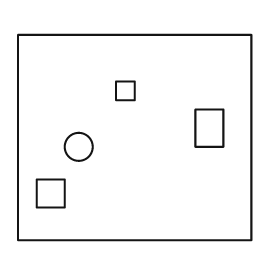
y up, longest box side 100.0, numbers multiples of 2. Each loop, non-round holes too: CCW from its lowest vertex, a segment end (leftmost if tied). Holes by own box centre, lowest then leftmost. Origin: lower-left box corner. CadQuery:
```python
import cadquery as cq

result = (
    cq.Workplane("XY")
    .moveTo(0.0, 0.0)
    .lineTo(100.0, 0.0)
    .lineTo(100.0, 88.0)
    .lineTo(0.0, 88.0)
    .close()
    .moveTo(8.0, 14.0)
    .lineTo(20.0, 14.0)
    .lineTo(20.0, 26.0)
    .lineTo(8.0, 26.0)
    .close()
    .moveTo(26.0, 40.0)
    .circle(6.0)
    .moveTo(76.0, 40.0)
    .lineTo(88.0, 40.0)
    .lineTo(88.0, 56.0)
    .lineTo(76.0, 56.0)
    .close()
    .moveTo(42.0, 60.0)
    .lineTo(50.0, 60.0)
    .lineTo(50.0, 68.0)
    .lineTo(42.0, 68.0)
    .close()
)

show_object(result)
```